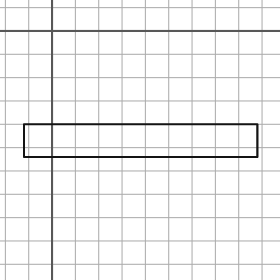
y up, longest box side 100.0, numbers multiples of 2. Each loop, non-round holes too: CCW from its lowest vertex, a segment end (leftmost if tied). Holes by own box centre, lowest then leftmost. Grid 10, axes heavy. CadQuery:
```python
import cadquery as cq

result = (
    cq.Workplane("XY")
    .moveTo(-12.0, -54.0)
    .lineTo(88.0, -54.0)
    .lineTo(88.0, -40.0)
    .lineTo(-12.0, -40.0)
    .close()
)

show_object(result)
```